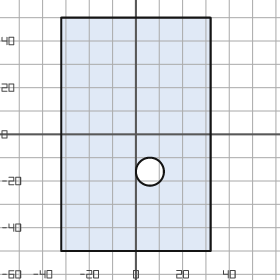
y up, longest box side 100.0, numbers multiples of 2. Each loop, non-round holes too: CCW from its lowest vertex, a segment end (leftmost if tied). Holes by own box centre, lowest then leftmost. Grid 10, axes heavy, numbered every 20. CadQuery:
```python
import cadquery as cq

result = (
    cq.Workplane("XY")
    .moveTo(-32.0, -50.0)
    .lineTo(32.0, -50.0)
    .lineTo(32.0, 50.0)
    .lineTo(-32.0, 50.0)
    .close()
    .moveTo(6.0, -16.0)
    .circle(6.0)
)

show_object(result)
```